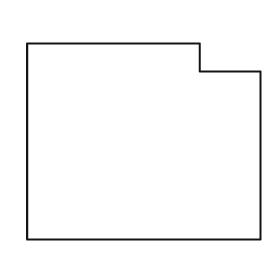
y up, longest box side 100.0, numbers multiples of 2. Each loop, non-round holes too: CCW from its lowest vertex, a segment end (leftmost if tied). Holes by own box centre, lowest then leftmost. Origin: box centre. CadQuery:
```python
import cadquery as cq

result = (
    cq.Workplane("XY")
    .moveTo(-50.0, -42.0)
    .lineTo(50.0, -42.0)
    .lineTo(50.0, 30.0)
    .lineTo(24.0, 30.0)
    .lineTo(24.0, 42.0)
    .lineTo(-50.0, 42.0)
    .close()
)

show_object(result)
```